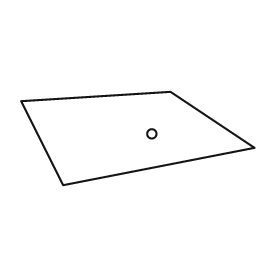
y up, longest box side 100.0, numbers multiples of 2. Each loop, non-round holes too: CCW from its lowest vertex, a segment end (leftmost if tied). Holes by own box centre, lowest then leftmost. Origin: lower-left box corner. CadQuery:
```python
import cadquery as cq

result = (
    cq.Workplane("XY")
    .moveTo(18.0, 0.0)
    .lineTo(100.0, 16.0)
    .lineTo(64.0, 40.0)
    .lineTo(0.0, 36.0)
    .close()
    .moveTo(56.0, 22.0)
    .circle(2.0)
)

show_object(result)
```